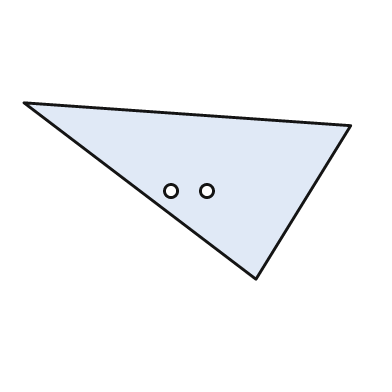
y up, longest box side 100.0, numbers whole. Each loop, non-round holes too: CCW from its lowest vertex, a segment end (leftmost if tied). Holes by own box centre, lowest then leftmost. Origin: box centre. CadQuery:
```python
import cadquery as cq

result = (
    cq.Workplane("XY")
    .moveTo(21.0, -27.0)
    .lineTo(50.0, 20.0)
    .lineTo(-50.0, 27.0)
    .close()
    .moveTo(-5.0, 0.0)
    .circle(2.0)
    .moveTo(6.0, 0.0)
    .circle(2.0)
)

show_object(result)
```